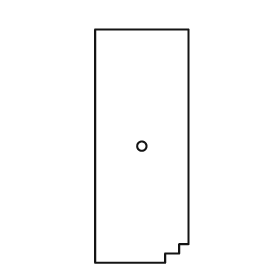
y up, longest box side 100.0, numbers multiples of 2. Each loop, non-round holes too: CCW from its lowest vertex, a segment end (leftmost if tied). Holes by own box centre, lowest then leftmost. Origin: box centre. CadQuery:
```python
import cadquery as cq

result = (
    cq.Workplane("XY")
    .moveTo(-20.0, -50.0)
    .lineTo(10.0, -50.0)
    .lineTo(10.0, -46.0)
    .lineTo(16.0, -46.0)
    .lineTo(16.0, -42.0)
    .lineTo(20.0, -42.0)
    .lineTo(20.0, 50.0)
    .lineTo(-20.0, 50.0)
    .close()
    .moveTo(0.0, 0.0)
    .circle(2.0)
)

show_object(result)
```